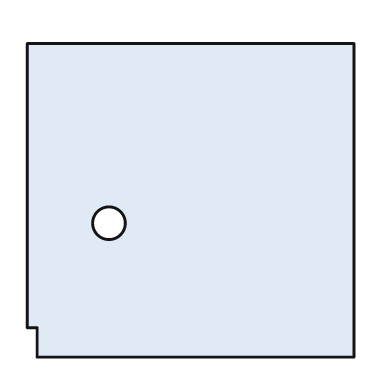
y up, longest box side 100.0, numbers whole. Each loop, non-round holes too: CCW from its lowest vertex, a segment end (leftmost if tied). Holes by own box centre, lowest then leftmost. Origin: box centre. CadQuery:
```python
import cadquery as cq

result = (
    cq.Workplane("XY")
    .moveTo(-47.0, -48.0)
    .lineTo(50.0, -48.0)
    .lineTo(50.0, 48.0)
    .lineTo(-50.0, 48.0)
    .lineTo(-50.0, -39.0)
    .lineTo(-47.0, -39.0)
    .close()
    .moveTo(-25.0, -7.0)
    .circle(5.0)
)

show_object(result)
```